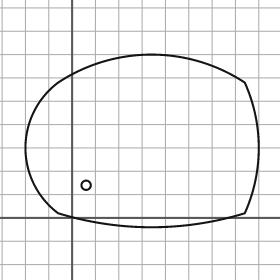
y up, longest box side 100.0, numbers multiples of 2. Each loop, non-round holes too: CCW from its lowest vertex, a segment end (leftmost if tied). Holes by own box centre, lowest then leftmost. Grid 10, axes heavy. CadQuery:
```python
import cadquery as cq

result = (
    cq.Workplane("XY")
    .moveTo(-6.0, 2.0)
    .threePointArc((34.0, -4.0), (74.0, 2.0))
    .threePointArc((80.0, 30.0), (74.0, 58.0))
    .threePointArc((34.0, 70.0), (-6.0, 58.0))
    .threePointArc((-20.0, 30.0), (-6.0, 2.0))
    .close()
    .moveTo(6.0, 14.0)
    .circle(2.0)
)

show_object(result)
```